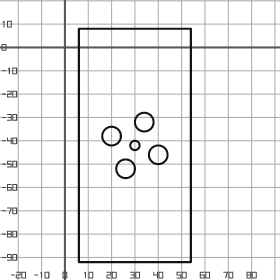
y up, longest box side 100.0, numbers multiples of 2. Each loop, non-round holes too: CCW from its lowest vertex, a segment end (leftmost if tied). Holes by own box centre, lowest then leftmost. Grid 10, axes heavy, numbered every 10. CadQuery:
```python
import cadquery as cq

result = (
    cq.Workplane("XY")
    .moveTo(6.0, -92.0)
    .lineTo(54.0, -92.0)
    .lineTo(54.0, 8.0)
    .lineTo(6.0, 8.0)
    .close()
    .moveTo(26.0, -52.0)
    .circle(4.0)
    .moveTo(40.0, -46.0)
    .circle(4.0)
    .moveTo(30.0, -42.0)
    .circle(2.0)
    .moveTo(20.0, -38.0)
    .circle(4.0)
    .moveTo(34.0, -32.0)
    .circle(4.0)
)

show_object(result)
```